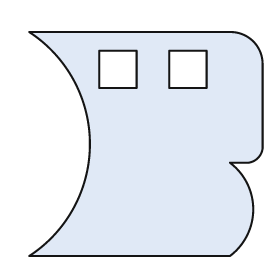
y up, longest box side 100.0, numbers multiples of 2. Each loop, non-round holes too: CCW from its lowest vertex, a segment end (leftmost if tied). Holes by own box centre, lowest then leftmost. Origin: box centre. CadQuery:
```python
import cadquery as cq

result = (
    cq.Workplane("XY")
    .moveTo(-50.0, -48.0)
    .lineTo(36.0, -48.0)
    .threePointArc((46.0, -28.0), (36.0, -8.0))
    .lineTo(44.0, -8.0)
    .threePointArc((48.0, -6.0), (50.0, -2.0))
    .lineTo(50.0, 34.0)
    .threePointArc((46.0, 44.0), (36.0, 48.0))
    .lineTo(-50.0, 48.0)
    .threePointArc((-24.0, 0.0), (-50.0, -48.0))
    .close()
    .moveTo(-20.0, 24.0)
    .lineTo(-4.0, 24.0)
    .lineTo(-4.0, 40.0)
    .lineTo(-20.0, 40.0)
    .close()
    .moveTo(10.0, 24.0)
    .lineTo(26.0, 24.0)
    .lineTo(26.0, 40.0)
    .lineTo(10.0, 40.0)
    .close()
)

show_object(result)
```